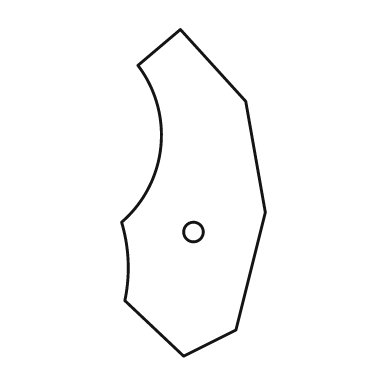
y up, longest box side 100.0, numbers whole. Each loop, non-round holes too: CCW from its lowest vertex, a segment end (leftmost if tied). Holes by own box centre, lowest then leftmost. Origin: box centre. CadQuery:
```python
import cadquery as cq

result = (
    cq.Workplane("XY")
    .moveTo(-3.0, -50.0)
    .lineTo(13.0, -42.0)
    .lineTo(22.0, -6.0)
    .lineTo(16.0, 28.0)
    .lineTo(-4.0, 50.0)
    .lineTo(-17.0, 39.0)
    .threePointArc((-10.0, 14.0), (-22.0, -9.0))
    .threePointArc((-20.0, -21.0), (-21.0, -33.0))
    .close()
    .moveTo(0.0, -12.0)
    .circle(3.0)
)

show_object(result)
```